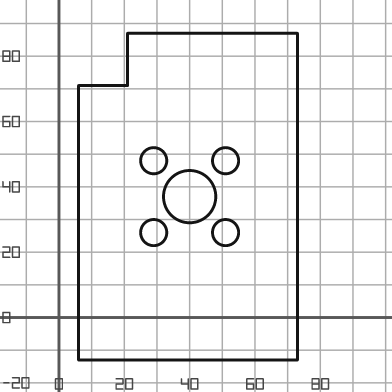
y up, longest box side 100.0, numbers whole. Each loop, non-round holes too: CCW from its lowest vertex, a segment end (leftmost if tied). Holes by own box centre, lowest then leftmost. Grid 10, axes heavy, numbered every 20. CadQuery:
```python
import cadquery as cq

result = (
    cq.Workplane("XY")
    .moveTo(6.0, -13.0)
    .lineTo(73.0, -13.0)
    .lineTo(73.0, 87.0)
    .lineTo(21.0, 87.0)
    .lineTo(21.0, 71.0)
    .lineTo(6.0, 71.0)
    .close()
    .moveTo(29.0, 26.0)
    .circle(4.0)
    .moveTo(51.0, 26.0)
    .circle(4.0)
    .moveTo(40.0, 37.0)
    .circle(8.0)
    .moveTo(29.0, 48.0)
    .circle(4.0)
    .moveTo(51.0, 48.0)
    .circle(4.0)
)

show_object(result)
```